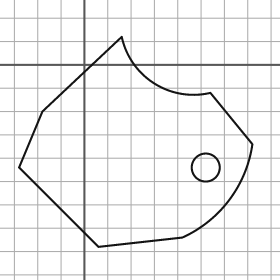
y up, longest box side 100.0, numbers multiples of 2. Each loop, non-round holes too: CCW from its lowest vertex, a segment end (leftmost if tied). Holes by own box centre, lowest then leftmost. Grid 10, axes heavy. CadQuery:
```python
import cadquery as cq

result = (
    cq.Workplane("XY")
    .moveTo(6.0, -78.0)
    .lineTo(42.0, -74.0)
    .threePointArc((62.0, -58.0), (72.0, -34.0))
    .lineTo(54.0, -12.0)
    .threePointArc((30.0, -8.0), (16.0, 12.0))
    .lineTo(-18.0, -20.0)
    .lineTo(-28.0, -44.0)
    .close()
    .moveTo(52.0, -44.0)
    .circle(6.0)
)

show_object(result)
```